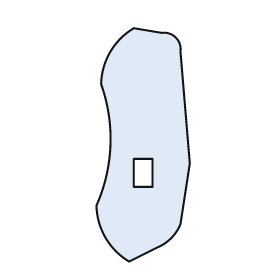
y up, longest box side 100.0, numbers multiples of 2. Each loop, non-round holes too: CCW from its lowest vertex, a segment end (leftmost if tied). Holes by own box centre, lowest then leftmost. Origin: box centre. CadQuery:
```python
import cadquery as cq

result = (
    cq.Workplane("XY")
    .moveTo(-6.0, -50.0)
    .lineTo(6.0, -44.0)
    .threePointArc((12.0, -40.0), (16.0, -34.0))
    .lineTo(20.0, -8.0)
    .lineTo(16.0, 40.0)
    .threePointArc((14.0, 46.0), (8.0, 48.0))
    .lineTo(-4.0, 50.0)
    .threePointArc((-14.0, 40.0), (-18.0, 26.0))
    .threePointArc((-14.0, 0.0), (-20.0, -26.0))
    .threePointArc((-16.0, -40.0), (-6.0, -50.0))
    .close()
    .moveTo(-4.0, -18.0)
    .lineTo(4.0, -18.0)
    .lineTo(4.0, -6.0)
    .lineTo(-4.0, -6.0)
    .close()
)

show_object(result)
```